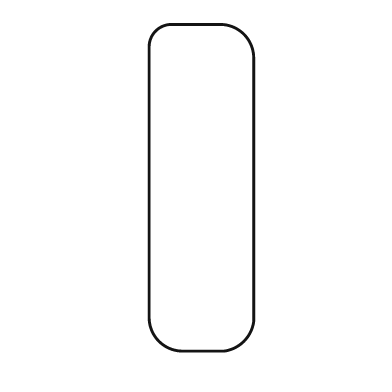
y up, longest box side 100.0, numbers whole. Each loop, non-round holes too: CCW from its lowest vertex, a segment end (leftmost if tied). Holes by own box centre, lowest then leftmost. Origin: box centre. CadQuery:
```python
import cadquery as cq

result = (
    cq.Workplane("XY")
    .moveTo(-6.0, -50.0)
    .lineTo(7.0, -50.0)
    .threePointArc((13.0, -47.0), (16.0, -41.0))
    .lineTo(16.0, 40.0)
    .threePointArc((13.0, 47.0), (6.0, 50.0))
    .lineTo(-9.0, 50.0)
    .threePointArc((-14.0, 48.0), (-16.0, 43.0))
    .lineTo(-16.0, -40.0)
    .threePointArc((-13.0, -47.0), (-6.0, -50.0))
    .close()
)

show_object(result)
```